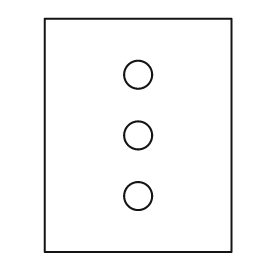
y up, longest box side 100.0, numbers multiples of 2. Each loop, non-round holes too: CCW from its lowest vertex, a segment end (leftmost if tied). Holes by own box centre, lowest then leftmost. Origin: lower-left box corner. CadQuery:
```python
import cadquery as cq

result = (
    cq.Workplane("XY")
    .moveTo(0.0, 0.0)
    .lineTo(80.0, 0.0)
    .lineTo(80.0, 100.0)
    .lineTo(0.0, 100.0)
    .close()
    .moveTo(40.0, 24.0)
    .circle(6.0)
    .moveTo(40.0, 50.0)
    .circle(6.0)
    .moveTo(40.0, 76.0)
    .circle(6.0)
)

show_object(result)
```